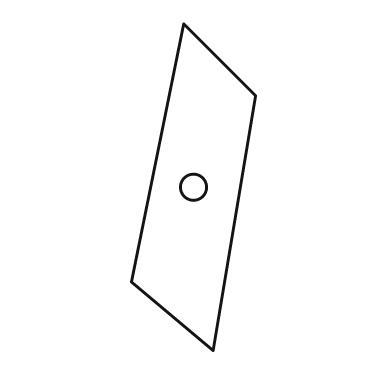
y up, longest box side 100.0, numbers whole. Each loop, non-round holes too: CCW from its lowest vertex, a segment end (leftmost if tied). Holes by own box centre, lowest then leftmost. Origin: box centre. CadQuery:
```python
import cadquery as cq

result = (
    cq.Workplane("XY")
    .moveTo(6.0, -50.0)
    .lineTo(19.0, 28.0)
    .lineTo(-3.0, 50.0)
    .lineTo(-19.0, -29.0)
    .close()
    .moveTo(0.0, 0.0)
    .circle(4.0)
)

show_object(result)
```